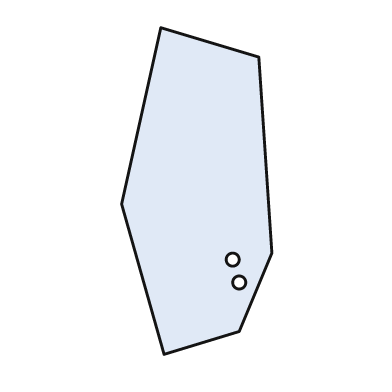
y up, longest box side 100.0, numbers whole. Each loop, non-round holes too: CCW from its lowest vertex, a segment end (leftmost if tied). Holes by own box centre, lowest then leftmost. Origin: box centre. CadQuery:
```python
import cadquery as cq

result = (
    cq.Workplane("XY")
    .moveTo(-10.0, -50.0)
    .lineTo(13.0, -43.0)
    .lineTo(23.0, -19.0)
    .lineTo(19.0, 41.0)
    .lineTo(-11.0, 50.0)
    .lineTo(-23.0, -4.0)
    .close()
    .moveTo(13.0, -28.0)
    .circle(2.0)
    .moveTo(11.0, -21.0)
    .circle(2.0)
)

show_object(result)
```